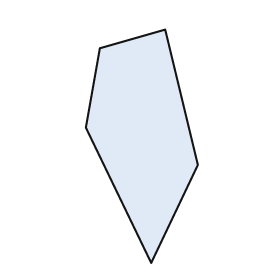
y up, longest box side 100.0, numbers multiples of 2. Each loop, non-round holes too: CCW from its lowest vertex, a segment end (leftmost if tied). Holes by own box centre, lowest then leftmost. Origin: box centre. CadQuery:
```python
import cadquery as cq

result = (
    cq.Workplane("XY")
    .moveTo(4.0, -50.0)
    .lineTo(24.0, -8.0)
    .lineTo(10.0, 50.0)
    .lineTo(-18.0, 42.0)
    .lineTo(-24.0, 8.0)
    .close()
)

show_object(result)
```